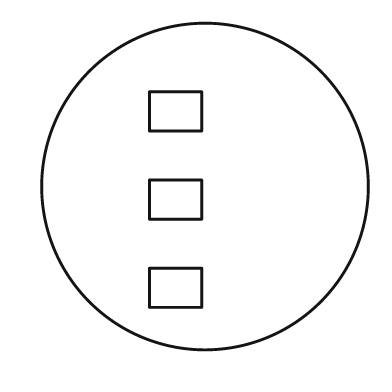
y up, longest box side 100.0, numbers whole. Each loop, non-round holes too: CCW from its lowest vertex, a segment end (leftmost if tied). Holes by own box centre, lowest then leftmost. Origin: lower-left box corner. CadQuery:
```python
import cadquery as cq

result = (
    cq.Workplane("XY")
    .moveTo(50.0, 50.0)
    .circle(50.0)
    .moveTo(33.0, 13.0)
    .lineTo(49.0, 13.0)
    .lineTo(49.0, 25.0)
    .lineTo(33.0, 25.0)
    .close()
    .moveTo(33.0, 40.0)
    .lineTo(49.0, 40.0)
    .lineTo(49.0, 52.0)
    .lineTo(33.0, 52.0)
    .close()
    .moveTo(33.0, 67.0)
    .lineTo(49.0, 67.0)
    .lineTo(49.0, 79.0)
    .lineTo(33.0, 79.0)
    .close()
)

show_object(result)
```